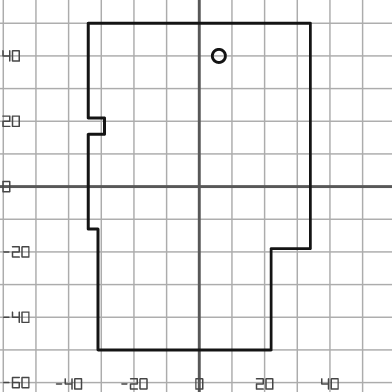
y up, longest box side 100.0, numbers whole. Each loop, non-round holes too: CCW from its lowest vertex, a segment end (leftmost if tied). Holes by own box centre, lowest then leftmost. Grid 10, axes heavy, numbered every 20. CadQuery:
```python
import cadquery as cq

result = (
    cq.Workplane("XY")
    .moveTo(-31.0, -50.0)
    .lineTo(22.0, -50.0)
    .lineTo(22.0, -19.0)
    .lineTo(34.0, -19.0)
    .lineTo(34.0, 50.0)
    .lineTo(-34.0, 50.0)
    .lineTo(-34.0, 21.0)
    .lineTo(-29.0, 21.0)
    .lineTo(-29.0, 16.0)
    .lineTo(-34.0, 16.0)
    .lineTo(-34.0, -13.0)
    .lineTo(-31.0, -13.0)
    .close()
    .moveTo(6.0, 40.0)
    .circle(2.0)
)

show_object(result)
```